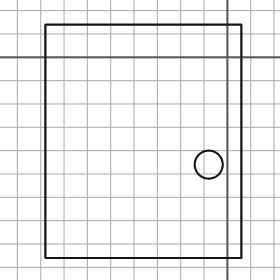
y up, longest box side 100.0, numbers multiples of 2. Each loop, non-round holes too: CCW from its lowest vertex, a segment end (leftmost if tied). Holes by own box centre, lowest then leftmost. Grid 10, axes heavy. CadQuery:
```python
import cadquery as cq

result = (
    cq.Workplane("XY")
    .moveTo(-78.0, -86.0)
    .lineTo(6.0, -86.0)
    .lineTo(6.0, 14.0)
    .lineTo(-78.0, 14.0)
    .close()
    .moveTo(-8.0, -46.0)
    .circle(6.0)
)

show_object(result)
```